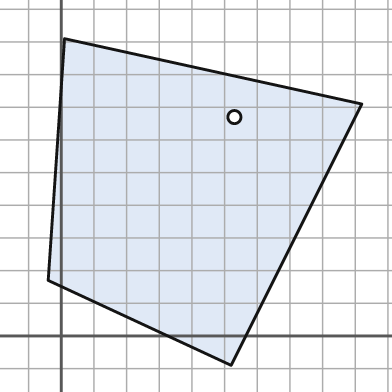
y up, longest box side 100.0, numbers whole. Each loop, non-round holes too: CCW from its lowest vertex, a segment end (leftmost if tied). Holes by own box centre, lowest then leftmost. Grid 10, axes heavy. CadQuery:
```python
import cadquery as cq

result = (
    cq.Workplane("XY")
    .moveTo(52.0, -9.0)
    .lineTo(92.0, 71.0)
    .lineTo(1.0, 91.0)
    .lineTo(-4.0, 17.0)
    .close()
    .moveTo(53.0, 67.0)
    .circle(2.0)
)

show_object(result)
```